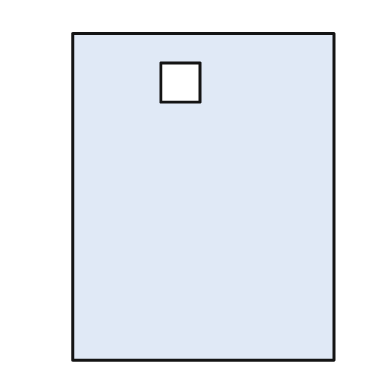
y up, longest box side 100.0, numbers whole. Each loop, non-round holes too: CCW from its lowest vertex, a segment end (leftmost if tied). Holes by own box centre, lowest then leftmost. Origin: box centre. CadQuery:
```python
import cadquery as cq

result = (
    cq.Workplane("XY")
    .moveTo(-40.0, -50.0)
    .lineTo(40.0, -50.0)
    .lineTo(40.0, 50.0)
    .lineTo(-40.0, 50.0)
    .close()
    .moveTo(-13.0, 29.0)
    .lineTo(-1.0, 29.0)
    .lineTo(-1.0, 41.0)
    .lineTo(-13.0, 41.0)
    .close()
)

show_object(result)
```